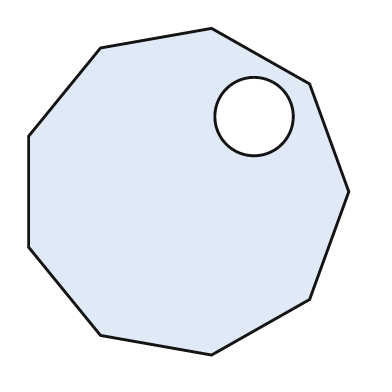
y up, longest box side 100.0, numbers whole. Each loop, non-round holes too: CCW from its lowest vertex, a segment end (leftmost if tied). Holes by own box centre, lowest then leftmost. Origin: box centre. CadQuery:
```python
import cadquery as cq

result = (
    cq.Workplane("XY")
    .moveTo(7.0, -50.0)
    .lineTo(37.0, -33.0)
    .lineTo(49.0, 0.0)
    .lineTo(37.0, 33.0)
    .lineTo(7.0, 50.0)
    .lineTo(-27.0, 44.0)
    .lineTo(-49.0, 17.0)
    .lineTo(-49.0, -17.0)
    .lineTo(-27.0, -44.0)
    .close()
    .moveTo(20.0, 23.0)
    .circle(12.0)
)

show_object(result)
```